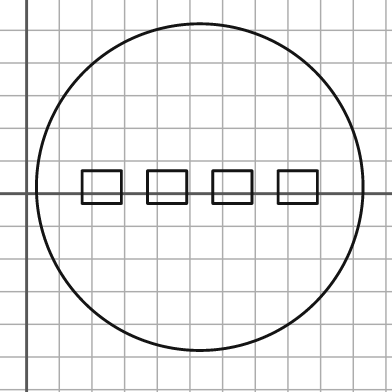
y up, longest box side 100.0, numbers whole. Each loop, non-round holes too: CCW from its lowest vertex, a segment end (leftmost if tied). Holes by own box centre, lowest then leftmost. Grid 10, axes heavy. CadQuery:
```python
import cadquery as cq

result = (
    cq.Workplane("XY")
    .moveTo(53.0, 2.0)
    .circle(50.0)
    .moveTo(17.0, -3.0)
    .lineTo(29.0, -3.0)
    .lineTo(29.0, 7.0)
    .lineTo(17.0, 7.0)
    .close()
    .moveTo(37.0, -3.0)
    .lineTo(49.0, -3.0)
    .lineTo(49.0, 7.0)
    .lineTo(37.0, 7.0)
    .close()
    .moveTo(57.0, -3.0)
    .lineTo(69.0, -3.0)
    .lineTo(69.0, 7.0)
    .lineTo(57.0, 7.0)
    .close()
    .moveTo(77.0, -3.0)
    .lineTo(89.0, -3.0)
    .lineTo(89.0, 7.0)
    .lineTo(77.0, 7.0)
    .close()
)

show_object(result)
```